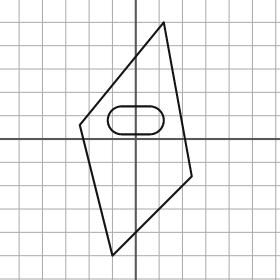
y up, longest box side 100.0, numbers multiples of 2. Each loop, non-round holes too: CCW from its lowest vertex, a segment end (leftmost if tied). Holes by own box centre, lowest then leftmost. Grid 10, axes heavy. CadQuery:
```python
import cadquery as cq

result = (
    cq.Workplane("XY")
    .moveTo(-10.0, -50.0)
    .lineTo(24.0, -16.0)
    .lineTo(12.0, 50.0)
    .lineTo(-24.0, 6.0)
    .close()
    .moveTo(-6.0, 2.0)
    .lineTo(6.0, 2.0)
    .threePointArc((12.0, 8.0), (6.0, 14.0))
    .lineTo(-6.0, 14.0)
    .threePointArc((-12.0, 8.0), (-6.0, 2.0))
    .close()
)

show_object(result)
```